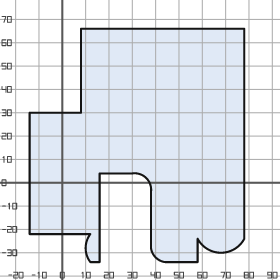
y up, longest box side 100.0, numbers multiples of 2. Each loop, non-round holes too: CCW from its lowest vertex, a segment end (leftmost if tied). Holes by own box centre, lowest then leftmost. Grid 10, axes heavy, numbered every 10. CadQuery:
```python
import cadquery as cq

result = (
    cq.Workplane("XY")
    .moveTo(12.0, -34.0)
    .lineTo(16.0, -34.0)
    .lineTo(16.0, 4.0)
    .lineTo(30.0, 4.0)
    .threePointArc((36.0, 2.0), (38.0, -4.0))
    .lineTo(38.0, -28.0)
    .threePointArc((40.0, -32.0), (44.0, -34.0))
    .lineTo(58.0, -34.0)
    .lineTo(58.0, -24.0)
    .threePointArc((68.0, -30.0), (78.0, -24.0))
    .lineTo(78.0, 66.0)
    .lineTo(8.0, 66.0)
    .lineTo(8.0, 30.0)
    .lineTo(-14.0, 30.0)
    .lineTo(-14.0, -22.0)
    .lineTo(12.0, -22.0)
    .threePointArc((10.0, -28.0), (12.0, -34.0))
    .close()
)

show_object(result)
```